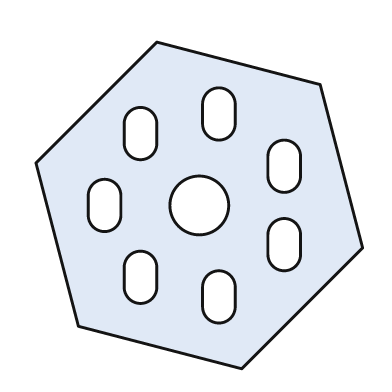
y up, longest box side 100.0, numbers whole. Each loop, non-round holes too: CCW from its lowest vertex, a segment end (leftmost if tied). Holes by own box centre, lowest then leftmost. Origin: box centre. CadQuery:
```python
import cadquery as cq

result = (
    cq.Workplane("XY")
    .moveTo(13.0, -50.0)
    .lineTo(50.0, -13.0)
    .lineTo(37.0, 37.0)
    .lineTo(-13.0, 50.0)
    .lineTo(-50.0, 13.0)
    .lineTo(-37.0, -37.0)
    .close()
    .moveTo(1.0, -31.0)
    .threePointArc((6.0, -36.0), (11.0, -31.0))
    .lineTo(11.0, -25.0)
    .threePointArc((6.0, -20.0), (1.0, -25.0))
    .close()
    .moveTo(-23.0, -25.0)
    .threePointArc((-18.0, -30.0), (-13.0, -25.0))
    .lineTo(-13.0, -19.0)
    .threePointArc((-18.0, -14.0), (-23.0, -19.0))
    .close()
    .moveTo(21.0, -15.0)
    .threePointArc((26.0, -20.0), (31.0, -15.0))
    .lineTo(31.0, -9.0)
    .threePointArc((26.0, -4.0), (21.0, -9.0))
    .close()
    .moveTo(-34.0, -3.0)
    .threePointArc((-29.0, -8.0), (-24.0, -3.0))
    .lineTo(-24.0, 3.0)
    .threePointArc((-29.0, 8.0), (-34.0, 3.0))
    .close()
    .moveTo(0.0, 0.0)
    .circle(9.0)
    .moveTo(21.0, 9.0)
    .threePointArc((26.0, 4.0), (31.0, 9.0))
    .lineTo(31.0, 15.0)
    .threePointArc((26.0, 20.0), (21.0, 15.0))
    .close()
    .moveTo(-23.0, 19.0)
    .threePointArc((-18.0, 14.0), (-13.0, 19.0))
    .lineTo(-13.0, 25.0)
    .threePointArc((-18.0, 30.0), (-23.0, 25.0))
    .close()
    .moveTo(1.0, 25.0)
    .threePointArc((6.0, 20.0), (11.0, 25.0))
    .lineTo(11.0, 31.0)
    .threePointArc((6.0, 36.0), (1.0, 31.0))
    .close()
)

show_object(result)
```